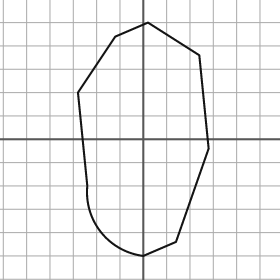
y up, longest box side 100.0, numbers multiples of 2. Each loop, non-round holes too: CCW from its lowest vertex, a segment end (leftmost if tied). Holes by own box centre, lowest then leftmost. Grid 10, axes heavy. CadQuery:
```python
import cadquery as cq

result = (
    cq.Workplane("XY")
    .moveTo(0.0, -50.0)
    .lineTo(14.0, -44.0)
    .lineTo(28.0, -4.0)
    .lineTo(24.0, 36.0)
    .lineTo(2.0, 50.0)
    .lineTo(-12.0, 44.0)
    .lineTo(-28.0, 20.0)
    .lineTo(-24.0, -20.0)
    .threePointArc((-18.0, -40.0), (0.0, -50.0))
    .close()
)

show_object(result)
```